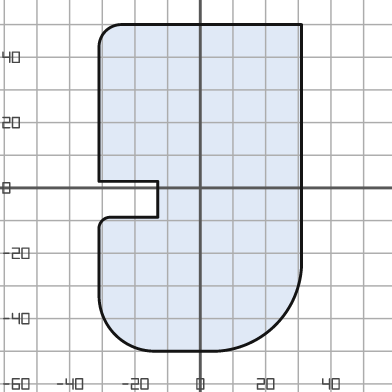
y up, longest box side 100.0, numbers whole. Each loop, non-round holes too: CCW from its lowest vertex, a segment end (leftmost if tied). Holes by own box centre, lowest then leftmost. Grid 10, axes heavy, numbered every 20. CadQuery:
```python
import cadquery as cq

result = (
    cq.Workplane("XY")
    .moveTo(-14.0, -50.0)
    .lineTo(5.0, -50.0)
    .threePointArc((23.0, -42.0), (31.0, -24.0))
    .lineTo(31.0, 50.0)
    .lineTo(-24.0, 50.0)
    .threePointArc((-29.0, 48.0), (-31.0, 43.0))
    .lineTo(-31.0, 2.0)
    .lineTo(-13.0, 2.0)
    .lineTo(-13.0, -9.0)
    .lineTo(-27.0, -9.0)
    .threePointArc((-30.0, -10.0), (-31.0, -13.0))
    .lineTo(-31.0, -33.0)
    .threePointArc((-26.0, -45.0), (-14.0, -50.0))
    .close()
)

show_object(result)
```